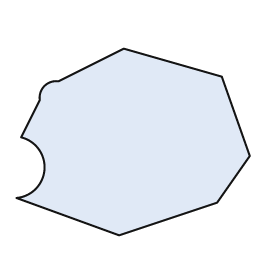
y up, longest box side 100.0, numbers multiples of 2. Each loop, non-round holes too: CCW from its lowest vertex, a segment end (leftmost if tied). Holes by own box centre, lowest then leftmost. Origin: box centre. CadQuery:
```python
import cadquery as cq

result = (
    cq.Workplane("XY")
    .moveTo(-6.0, -40.0)
    .lineTo(36.0, -26.0)
    .lineTo(50.0, -6.0)
    .lineTo(38.0, 28.0)
    .lineTo(-4.0, 40.0)
    .lineTo(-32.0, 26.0)
    .threePointArc((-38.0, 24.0), (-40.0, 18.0))
    .lineTo(-48.0, 2.0)
    .threePointArc((-38.0, -12.0), (-50.0, -24.0))
    .close()
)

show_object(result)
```